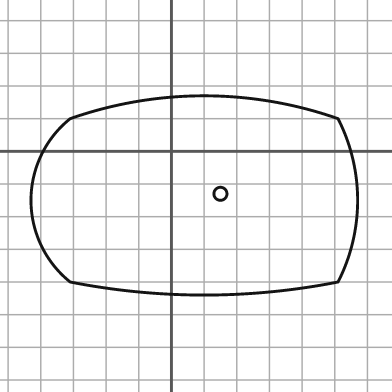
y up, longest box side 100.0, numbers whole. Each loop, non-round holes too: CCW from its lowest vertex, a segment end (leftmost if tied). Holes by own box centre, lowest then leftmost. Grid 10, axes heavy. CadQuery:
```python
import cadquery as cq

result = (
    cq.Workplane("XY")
    .moveTo(-31.0, -40.0)
    .threePointArc((10.0, -44.0), (51.0, -40.0))
    .threePointArc((57.0, -15.0), (51.0, 10.0))
    .threePointArc((10.0, 17.0), (-31.0, 10.0))
    .threePointArc((-43.0, -15.0), (-31.0, -40.0))
    .close()
    .moveTo(15.0, -13.0)
    .circle(2.0)
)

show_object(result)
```